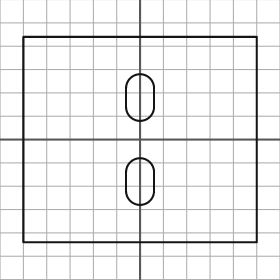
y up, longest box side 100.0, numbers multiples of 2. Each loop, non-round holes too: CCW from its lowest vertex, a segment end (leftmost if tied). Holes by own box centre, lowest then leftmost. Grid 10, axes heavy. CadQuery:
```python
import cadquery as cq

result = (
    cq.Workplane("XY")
    .moveTo(-50.0, -44.0)
    .lineTo(50.0, -44.0)
    .lineTo(50.0, 44.0)
    .lineTo(-50.0, 44.0)
    .close()
    .moveTo(-6.0, -22.0)
    .threePointArc((0.0, -28.0), (6.0, -22.0))
    .lineTo(6.0, -14.0)
    .threePointArc((0.0, -8.0), (-6.0, -14.0))
    .close()
    .moveTo(-6.0, 14.0)
    .threePointArc((0.0, 8.0), (6.0, 14.0))
    .lineTo(6.0, 22.0)
    .threePointArc((0.0, 28.0), (-6.0, 22.0))
    .close()
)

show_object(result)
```